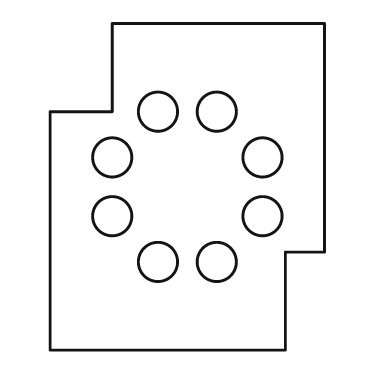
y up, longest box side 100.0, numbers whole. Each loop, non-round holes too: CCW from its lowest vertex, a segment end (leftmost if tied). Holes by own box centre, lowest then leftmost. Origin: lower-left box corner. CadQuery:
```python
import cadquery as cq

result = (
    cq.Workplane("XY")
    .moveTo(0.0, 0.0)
    .lineTo(72.0, 0.0)
    .lineTo(72.0, 30.0)
    .lineTo(84.0, 30.0)
    .lineTo(84.0, 100.0)
    .lineTo(19.0, 100.0)
    .lineTo(19.0, 73.0)
    .lineTo(0.0, 73.0)
    .close()
    .moveTo(33.0, 27.0)
    .circle(6.0)
    .moveTo(51.0, 27.0)
    .circle(6.0)
    .moveTo(19.0, 41.0)
    .circle(6.0)
    .moveTo(65.0, 41.0)
    .circle(6.0)
    .moveTo(19.0, 59.0)
    .circle(6.0)
    .moveTo(65.0, 59.0)
    .circle(6.0)
    .moveTo(33.0, 73.0)
    .circle(6.0)
    .moveTo(51.0, 73.0)
    .circle(6.0)
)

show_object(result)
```